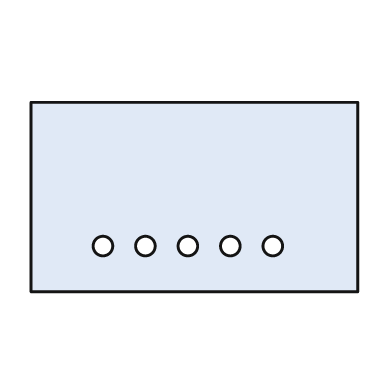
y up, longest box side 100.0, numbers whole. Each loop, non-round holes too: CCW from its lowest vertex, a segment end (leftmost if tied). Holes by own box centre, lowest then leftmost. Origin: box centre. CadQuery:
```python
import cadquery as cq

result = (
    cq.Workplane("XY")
    .moveTo(-50.0, -29.0)
    .lineTo(50.0, -29.0)
    .lineTo(50.0, 29.0)
    .lineTo(-50.0, 29.0)
    .close()
    .moveTo(-28.0, -15.0)
    .circle(3.0)
    .moveTo(-15.0, -15.0)
    .circle(3.0)
    .moveTo(-2.0, -15.0)
    .circle(3.0)
    .moveTo(11.0, -15.0)
    .circle(3.0)
    .moveTo(24.0, -15.0)
    .circle(3.0)
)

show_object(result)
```